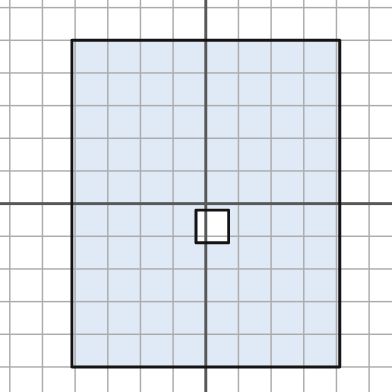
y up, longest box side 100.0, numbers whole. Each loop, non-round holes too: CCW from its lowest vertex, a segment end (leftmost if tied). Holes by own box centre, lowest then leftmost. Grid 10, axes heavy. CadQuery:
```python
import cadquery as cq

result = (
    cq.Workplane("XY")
    .moveTo(-41.0, -50.0)
    .lineTo(41.0, -50.0)
    .lineTo(41.0, 50.0)
    .lineTo(-41.0, 50.0)
    .close()
    .moveTo(-3.0, -12.0)
    .lineTo(7.0, -12.0)
    .lineTo(7.0, -2.0)
    .lineTo(-3.0, -2.0)
    .close()
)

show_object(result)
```